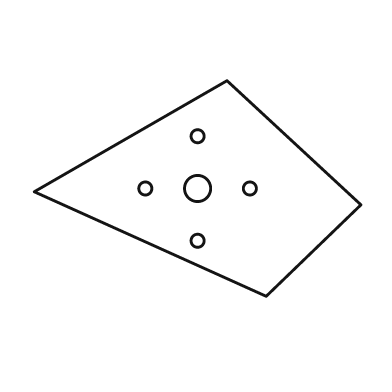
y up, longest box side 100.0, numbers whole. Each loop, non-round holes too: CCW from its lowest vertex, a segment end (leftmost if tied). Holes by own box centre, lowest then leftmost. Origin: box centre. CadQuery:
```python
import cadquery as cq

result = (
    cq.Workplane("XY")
    .moveTo(21.0, -33.0)
    .lineTo(50.0, -5.0)
    .lineTo(9.0, 33.0)
    .lineTo(-50.0, -1.0)
    .close()
    .moveTo(0.0, -16.0)
    .circle(2.0)
    .moveTo(-16.0, 0.0)
    .circle(2.0)
    .moveTo(0.0, 0.0)
    .circle(4.0)
    .moveTo(16.0, 0.0)
    .circle(2.0)
    .moveTo(0.0, 16.0)
    .circle(2.0)
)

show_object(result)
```